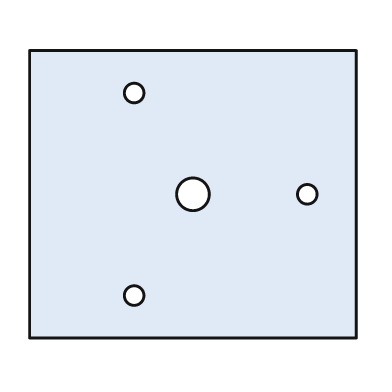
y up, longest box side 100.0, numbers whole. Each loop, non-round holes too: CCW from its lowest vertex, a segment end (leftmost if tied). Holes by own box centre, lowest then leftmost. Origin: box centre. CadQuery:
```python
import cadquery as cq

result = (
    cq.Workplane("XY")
    .moveTo(-50.0, -44.0)
    .lineTo(50.0, -44.0)
    .lineTo(50.0, 44.0)
    .lineTo(-50.0, 44.0)
    .close()
    .moveTo(-18.0, -31.0)
    .circle(3.0)
    .moveTo(0.0, 0.0)
    .circle(5.0)
    .moveTo(35.0, 0.0)
    .circle(3.0)
    .moveTo(-18.0, 31.0)
    .circle(3.0)
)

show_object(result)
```